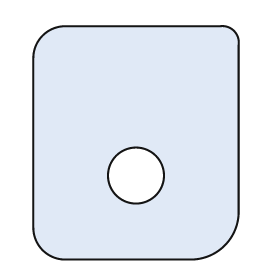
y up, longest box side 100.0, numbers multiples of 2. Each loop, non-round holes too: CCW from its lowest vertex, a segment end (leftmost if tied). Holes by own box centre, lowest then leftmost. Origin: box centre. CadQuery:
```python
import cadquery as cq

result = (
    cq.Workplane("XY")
    .moveTo(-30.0, -50.0)
    .lineTo(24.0, -50.0)
    .threePointArc((38.0, -44.0), (44.0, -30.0))
    .lineTo(44.0, 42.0)
    .threePointArc((42.0, 48.0), (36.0, 50.0))
    .lineTo(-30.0, 50.0)
    .threePointArc((-40.0, 46.0), (-44.0, 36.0))
    .lineTo(-44.0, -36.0)
    .threePointArc((-40.0, -46.0), (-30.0, -50.0))
    .close()
    .moveTo(0.0, -14.0)
    .circle(12.0)
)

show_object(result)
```